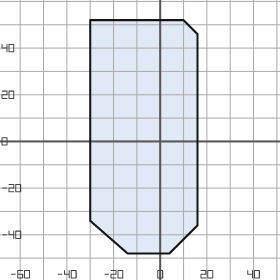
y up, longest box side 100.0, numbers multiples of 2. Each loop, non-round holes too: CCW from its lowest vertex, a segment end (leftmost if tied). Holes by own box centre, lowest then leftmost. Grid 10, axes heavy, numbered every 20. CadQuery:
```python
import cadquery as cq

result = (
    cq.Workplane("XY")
    .moveTo(-14.0, -48.0)
    .lineTo(4.0, -48.0)
    .lineTo(16.0, -36.0)
    .lineTo(16.0, 46.0)
    .lineTo(10.0, 52.0)
    .lineTo(-30.0, 52.0)
    .lineTo(-30.0, -34.0)
    .close()
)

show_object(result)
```